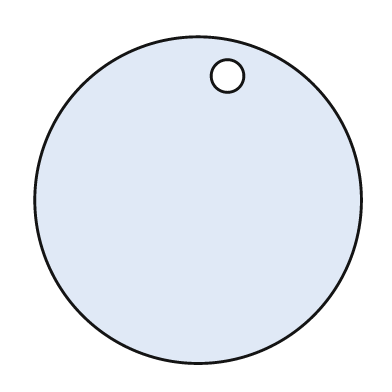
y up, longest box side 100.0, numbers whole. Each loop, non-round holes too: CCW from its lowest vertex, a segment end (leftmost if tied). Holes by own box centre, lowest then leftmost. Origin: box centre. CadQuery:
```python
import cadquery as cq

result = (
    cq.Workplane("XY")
    .moveTo(0.0, 0.0)
    .circle(50.0)
    .moveTo(9.0, 38.0)
    .circle(5.0)
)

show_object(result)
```